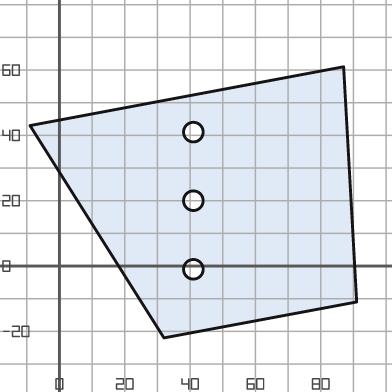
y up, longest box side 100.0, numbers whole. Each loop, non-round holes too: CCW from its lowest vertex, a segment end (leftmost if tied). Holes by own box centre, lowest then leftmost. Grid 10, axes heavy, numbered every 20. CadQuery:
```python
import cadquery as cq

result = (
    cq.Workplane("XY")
    .moveTo(32.0, -22.0)
    .lineTo(91.0, -11.0)
    .lineTo(87.0, 61.0)
    .lineTo(-9.0, 43.0)
    .close()
    .moveTo(41.0, -1.0)
    .circle(3.0)
    .moveTo(41.0, 20.0)
    .circle(3.0)
    .moveTo(41.0, 41.0)
    .circle(3.0)
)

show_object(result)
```